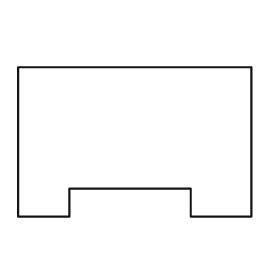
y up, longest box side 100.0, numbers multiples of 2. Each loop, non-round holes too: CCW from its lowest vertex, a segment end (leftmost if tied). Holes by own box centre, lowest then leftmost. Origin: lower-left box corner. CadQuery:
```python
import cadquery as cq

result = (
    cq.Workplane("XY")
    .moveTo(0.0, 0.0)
    .lineTo(22.0, 0.0)
    .lineTo(22.0, 12.0)
    .lineTo(74.0, 12.0)
    .lineTo(74.0, 0.0)
    .lineTo(100.0, 0.0)
    .lineTo(100.0, 64.0)
    .lineTo(0.0, 64.0)
    .close()
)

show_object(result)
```